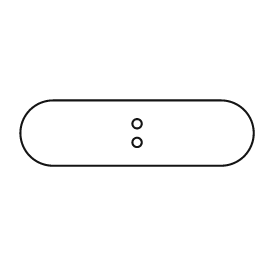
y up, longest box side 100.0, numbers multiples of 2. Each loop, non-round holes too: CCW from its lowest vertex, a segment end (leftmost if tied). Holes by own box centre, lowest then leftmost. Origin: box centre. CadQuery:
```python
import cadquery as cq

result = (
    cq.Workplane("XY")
    .moveTo(-36.0, -14.0)
    .lineTo(36.0, -14.0)
    .threePointArc((50.0, 0.0), (36.0, 14.0))
    .lineTo(-36.0, 14.0)
    .threePointArc((-50.0, 0.0), (-36.0, -14.0))
    .close()
    .moveTo(0.0, -4.0)
    .circle(2.0)
    .moveTo(0.0, 4.0)
    .circle(2.0)
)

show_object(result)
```